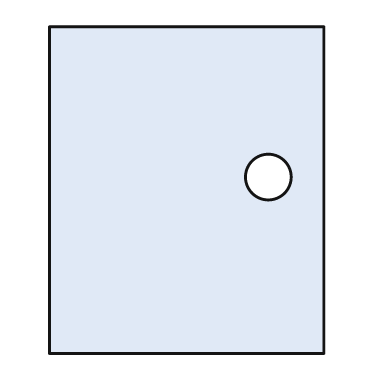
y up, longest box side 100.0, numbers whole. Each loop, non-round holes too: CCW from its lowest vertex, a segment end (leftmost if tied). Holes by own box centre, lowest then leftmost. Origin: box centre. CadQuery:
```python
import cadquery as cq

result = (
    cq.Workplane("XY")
    .moveTo(-42.0, -50.0)
    .lineTo(42.0, -50.0)
    .lineTo(42.0, 50.0)
    .lineTo(-42.0, 50.0)
    .close()
    .moveTo(25.0, 4.0)
    .circle(7.0)
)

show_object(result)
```